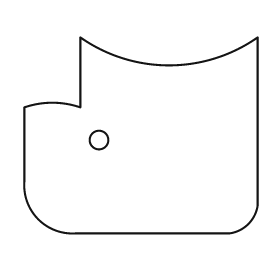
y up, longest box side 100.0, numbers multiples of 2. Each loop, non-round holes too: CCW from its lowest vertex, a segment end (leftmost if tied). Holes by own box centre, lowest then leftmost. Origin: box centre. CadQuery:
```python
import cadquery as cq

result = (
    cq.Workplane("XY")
    .moveTo(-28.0, -42.0)
    .lineTo(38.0, -42.0)
    .threePointArc((46.0, -38.0), (50.0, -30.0))
    .lineTo(50.0, 42.0)
    .threePointArc((12.0, 30.0), (-26.0, 42.0))
    .lineTo(-26.0, 12.0)
    .threePointArc((-38.0, 14.0), (-50.0, 12.0))
    .lineTo(-50.0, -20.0)
    .threePointArc((-44.0, -36.0), (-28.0, -42.0))
    .close()
    .moveTo(-18.0, -2.0)
    .circle(4.0)
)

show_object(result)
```